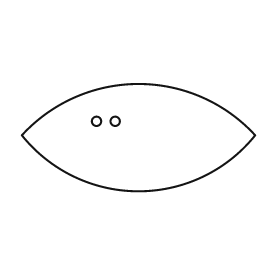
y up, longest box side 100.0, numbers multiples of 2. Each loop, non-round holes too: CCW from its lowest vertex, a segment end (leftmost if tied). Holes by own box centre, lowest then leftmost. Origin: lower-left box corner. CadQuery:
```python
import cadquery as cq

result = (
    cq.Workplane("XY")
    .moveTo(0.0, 24.0)
    .threePointArc((50.0, 0.0), (100.0, 24.0))
    .threePointArc((50.0, 46.0), (0.0, 24.0))
    .close()
    .moveTo(32.0, 30.0)
    .circle(2.0)
    .moveTo(40.0, 30.0)
    .circle(2.0)
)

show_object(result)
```